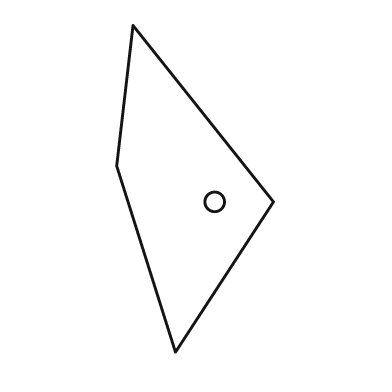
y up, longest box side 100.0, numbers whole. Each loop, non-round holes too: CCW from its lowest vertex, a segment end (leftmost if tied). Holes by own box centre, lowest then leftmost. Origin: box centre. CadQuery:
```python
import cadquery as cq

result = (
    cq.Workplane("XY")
    .moveTo(-6.0, -50.0)
    .lineTo(24.0, -4.0)
    .lineTo(-19.0, 50.0)
    .lineTo(-24.0, 7.0)
    .close()
    .moveTo(6.0, -4.0)
    .circle(3.0)
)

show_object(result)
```